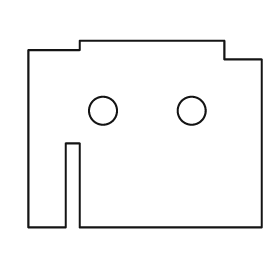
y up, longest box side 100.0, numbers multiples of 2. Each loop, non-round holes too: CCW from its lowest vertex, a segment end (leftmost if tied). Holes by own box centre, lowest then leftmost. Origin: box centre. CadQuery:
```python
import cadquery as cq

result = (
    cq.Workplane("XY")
    .moveTo(-50.0, -40.0)
    .lineTo(-34.0, -40.0)
    .lineTo(-34.0, -4.0)
    .lineTo(-28.0, -4.0)
    .lineTo(-28.0, -40.0)
    .lineTo(50.0, -40.0)
    .lineTo(50.0, 32.0)
    .lineTo(34.0, 32.0)
    .lineTo(34.0, 40.0)
    .lineTo(-28.0, 40.0)
    .lineTo(-28.0, 36.0)
    .lineTo(-50.0, 36.0)
    .close()
    .moveTo(-18.0, 10.0)
    .circle(6.0)
    .moveTo(20.0, 10.0)
    .circle(6.0)
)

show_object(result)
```